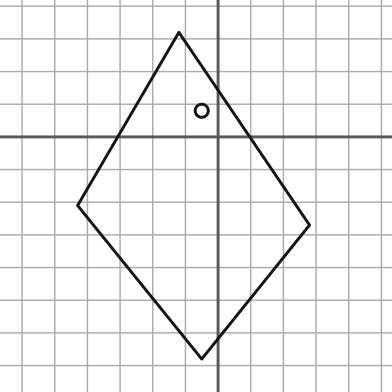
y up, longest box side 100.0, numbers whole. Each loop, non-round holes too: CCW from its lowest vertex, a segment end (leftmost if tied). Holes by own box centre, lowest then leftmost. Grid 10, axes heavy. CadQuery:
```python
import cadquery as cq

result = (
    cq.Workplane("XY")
    .moveTo(-5.0, -68.0)
    .lineTo(28.0, -27.0)
    .lineTo(-12.0, 32.0)
    .lineTo(-43.0, -21.0)
    .close()
    .moveTo(-5.0, 8.0)
    .circle(2.0)
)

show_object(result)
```